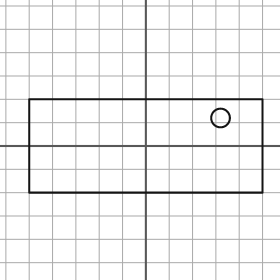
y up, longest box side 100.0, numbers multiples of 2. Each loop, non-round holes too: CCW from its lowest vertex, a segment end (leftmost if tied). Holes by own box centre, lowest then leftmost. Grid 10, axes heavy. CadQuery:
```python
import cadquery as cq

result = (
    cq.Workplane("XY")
    .moveTo(-50.0, -20.0)
    .lineTo(50.0, -20.0)
    .lineTo(50.0, 20.0)
    .lineTo(-50.0, 20.0)
    .close()
    .moveTo(32.0, 12.0)
    .circle(4.0)
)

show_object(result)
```